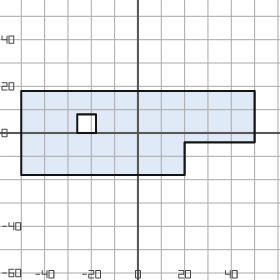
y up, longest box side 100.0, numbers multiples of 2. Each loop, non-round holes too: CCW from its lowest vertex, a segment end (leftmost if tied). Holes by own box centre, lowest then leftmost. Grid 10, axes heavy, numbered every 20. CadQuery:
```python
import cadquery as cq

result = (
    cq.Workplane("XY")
    .moveTo(-50.0, -18.0)
    .lineTo(20.0, -18.0)
    .lineTo(20.0, -4.0)
    .lineTo(50.0, -4.0)
    .lineTo(50.0, 18.0)
    .lineTo(-50.0, 18.0)
    .close()
    .moveTo(-26.0, 0.0)
    .lineTo(-18.0, 0.0)
    .lineTo(-18.0, 8.0)
    .lineTo(-26.0, 8.0)
    .close()
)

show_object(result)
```